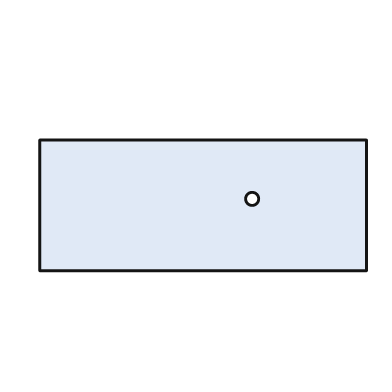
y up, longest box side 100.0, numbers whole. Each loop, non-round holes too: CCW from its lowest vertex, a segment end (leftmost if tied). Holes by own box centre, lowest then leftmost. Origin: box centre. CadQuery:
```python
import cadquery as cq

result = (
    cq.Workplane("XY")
    .moveTo(-50.0, -20.0)
    .lineTo(50.0, -20.0)
    .lineTo(50.0, 20.0)
    .lineTo(-50.0, 20.0)
    .close()
    .moveTo(15.0, 2.0)
    .circle(2.0)
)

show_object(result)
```